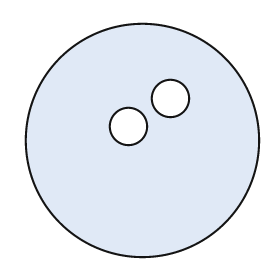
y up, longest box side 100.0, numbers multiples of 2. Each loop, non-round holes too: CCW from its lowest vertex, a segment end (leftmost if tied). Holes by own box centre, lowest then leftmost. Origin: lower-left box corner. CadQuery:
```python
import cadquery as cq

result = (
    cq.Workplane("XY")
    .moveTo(50.0, 50.0)
    .circle(50.0)
    .moveTo(44.0, 56.0)
    .circle(8.0)
    .moveTo(62.0, 68.0)
    .circle(8.0)
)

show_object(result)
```